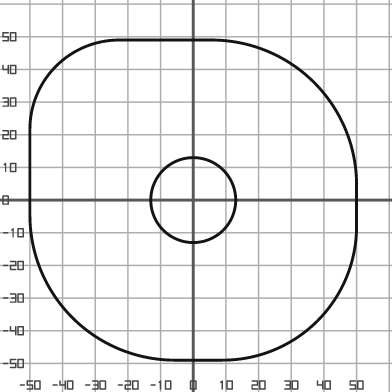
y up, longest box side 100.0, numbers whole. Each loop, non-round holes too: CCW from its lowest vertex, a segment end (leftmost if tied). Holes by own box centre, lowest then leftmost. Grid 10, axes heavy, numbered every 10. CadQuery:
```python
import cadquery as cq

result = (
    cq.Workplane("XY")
    .moveTo(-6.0, -49.0)
    .lineTo(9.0, -49.0)
    .threePointArc((38.0, -37.0), (50.0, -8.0))
    .lineTo(50.0, 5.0)
    .threePointArc((37.0, 36.0), (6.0, 49.0))
    .lineTo(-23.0, 49.0)
    .threePointArc((-42.0, 41.0), (-50.0, 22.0))
    .lineTo(-50.0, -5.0)
    .threePointArc((-37.0, -36.0), (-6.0, -49.0))
    .close()
    .moveTo(0.0, 0.0)
    .circle(13.0)
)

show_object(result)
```